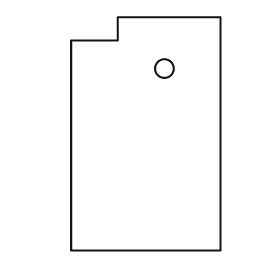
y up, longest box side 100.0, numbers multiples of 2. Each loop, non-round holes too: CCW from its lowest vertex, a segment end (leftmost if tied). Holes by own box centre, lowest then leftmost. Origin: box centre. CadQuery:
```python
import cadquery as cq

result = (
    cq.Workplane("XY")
    .moveTo(-32.0, -50.0)
    .lineTo(32.0, -50.0)
    .lineTo(32.0, 50.0)
    .lineTo(-12.0, 50.0)
    .lineTo(-12.0, 40.0)
    .lineTo(-32.0, 40.0)
    .close()
    .moveTo(8.0, 28.0)
    .circle(4.0)
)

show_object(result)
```